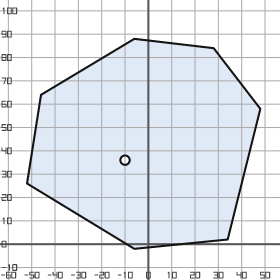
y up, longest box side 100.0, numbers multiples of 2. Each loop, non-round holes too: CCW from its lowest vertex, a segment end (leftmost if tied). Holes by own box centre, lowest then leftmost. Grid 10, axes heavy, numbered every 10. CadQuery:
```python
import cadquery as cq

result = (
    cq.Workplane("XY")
    .moveTo(-6.0, -2.0)
    .lineTo(34.0, 2.0)
    .lineTo(48.0, 58.0)
    .lineTo(28.0, 84.0)
    .lineTo(-6.0, 88.0)
    .lineTo(-46.0, 64.0)
    .lineTo(-52.0, 26.0)
    .close()
    .moveTo(-10.0, 36.0)
    .circle(2.0)
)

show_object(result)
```